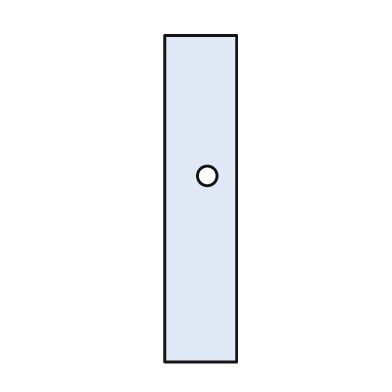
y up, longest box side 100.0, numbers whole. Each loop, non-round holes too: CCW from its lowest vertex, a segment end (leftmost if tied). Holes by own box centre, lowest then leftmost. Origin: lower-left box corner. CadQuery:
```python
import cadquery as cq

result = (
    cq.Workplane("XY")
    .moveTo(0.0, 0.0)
    .lineTo(22.0, 0.0)
    .lineTo(22.0, 100.0)
    .lineTo(0.0, 100.0)
    .close()
    .moveTo(13.0, 57.0)
    .circle(3.0)
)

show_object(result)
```